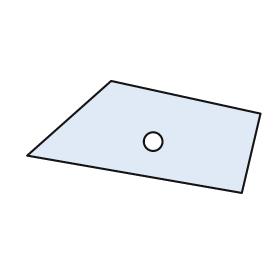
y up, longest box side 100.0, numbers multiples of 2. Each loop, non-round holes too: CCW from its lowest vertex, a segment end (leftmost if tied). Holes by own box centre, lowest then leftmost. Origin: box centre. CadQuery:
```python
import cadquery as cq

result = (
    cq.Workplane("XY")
    .moveTo(42.0, -24.0)
    .lineTo(50.0, 10.0)
    .lineTo(-14.0, 24.0)
    .lineTo(-50.0, -8.0)
    .close()
    .moveTo(4.0, -2.0)
    .circle(4.0)
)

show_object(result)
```